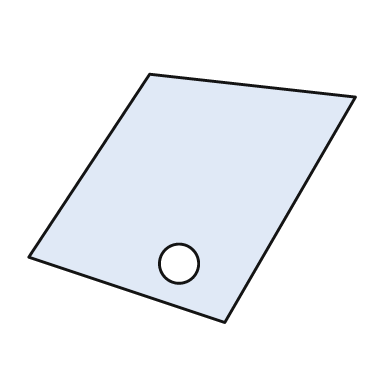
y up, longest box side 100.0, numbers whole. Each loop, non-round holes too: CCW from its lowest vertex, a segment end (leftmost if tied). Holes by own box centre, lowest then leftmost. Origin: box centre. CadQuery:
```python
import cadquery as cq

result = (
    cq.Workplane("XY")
    .moveTo(10.0, -38.0)
    .lineTo(50.0, 31.0)
    .lineTo(-13.0, 38.0)
    .lineTo(-50.0, -18.0)
    .close()
    .moveTo(-4.0, -20.0)
    .circle(6.0)
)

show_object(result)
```